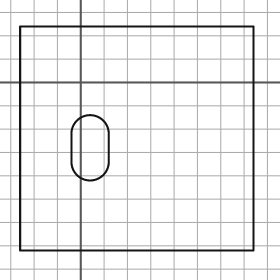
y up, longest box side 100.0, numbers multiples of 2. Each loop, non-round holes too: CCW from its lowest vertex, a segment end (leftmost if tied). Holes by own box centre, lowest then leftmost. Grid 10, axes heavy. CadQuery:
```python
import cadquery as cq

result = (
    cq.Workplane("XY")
    .moveTo(-26.0, -72.0)
    .lineTo(74.0, -72.0)
    .lineTo(74.0, 24.0)
    .lineTo(-26.0, 24.0)
    .close()
    .moveTo(-4.0, -34.0)
    .threePointArc((4.0, -42.0), (12.0, -34.0))
    .lineTo(12.0, -22.0)
    .threePointArc((4.0, -14.0), (-4.0, -22.0))
    .close()
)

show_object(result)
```